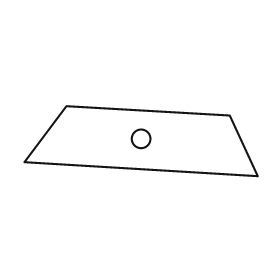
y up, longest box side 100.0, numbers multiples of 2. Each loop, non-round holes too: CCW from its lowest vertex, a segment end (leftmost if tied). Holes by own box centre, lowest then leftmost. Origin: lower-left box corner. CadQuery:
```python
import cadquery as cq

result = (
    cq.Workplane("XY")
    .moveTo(100.0, 0.0)
    .lineTo(88.0, 26.0)
    .lineTo(18.0, 30.0)
    .lineTo(0.0, 6.0)
    .close()
    .moveTo(50.0, 16.0)
    .circle(4.0)
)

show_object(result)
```